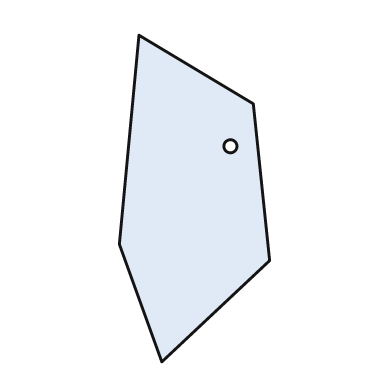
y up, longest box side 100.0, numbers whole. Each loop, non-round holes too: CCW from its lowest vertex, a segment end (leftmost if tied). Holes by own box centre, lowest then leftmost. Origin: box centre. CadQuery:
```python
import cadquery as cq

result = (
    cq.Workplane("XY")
    .moveTo(-10.0, -50.0)
    .lineTo(23.0, -19.0)
    .lineTo(18.0, 29.0)
    .lineTo(-17.0, 50.0)
    .lineTo(-23.0, -14.0)
    .close()
    .moveTo(11.0, 16.0)
    .circle(2.0)
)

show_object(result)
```